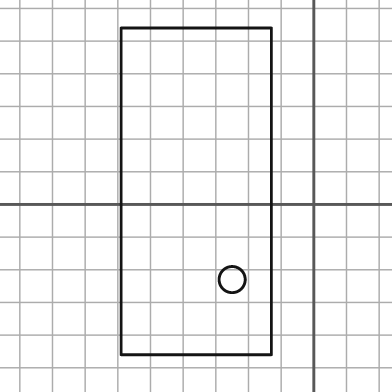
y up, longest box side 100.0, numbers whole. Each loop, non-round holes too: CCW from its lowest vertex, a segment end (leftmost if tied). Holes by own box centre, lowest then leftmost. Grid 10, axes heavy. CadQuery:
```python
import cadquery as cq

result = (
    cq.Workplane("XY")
    .moveTo(-59.0, -46.0)
    .lineTo(-13.0, -46.0)
    .lineTo(-13.0, 54.0)
    .lineTo(-59.0, 54.0)
    .close()
    .moveTo(-25.0, -23.0)
    .circle(4.0)
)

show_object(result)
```